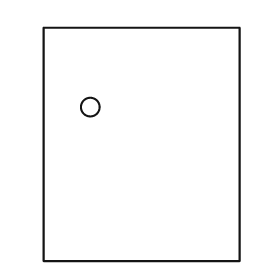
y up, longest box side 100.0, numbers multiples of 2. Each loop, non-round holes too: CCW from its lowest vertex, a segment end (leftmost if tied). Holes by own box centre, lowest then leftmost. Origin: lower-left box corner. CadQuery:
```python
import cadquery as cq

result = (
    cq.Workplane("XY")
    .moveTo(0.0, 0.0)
    .lineTo(84.0, 0.0)
    .lineTo(84.0, 100.0)
    .lineTo(0.0, 100.0)
    .close()
    .moveTo(20.0, 66.0)
    .circle(4.0)
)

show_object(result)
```